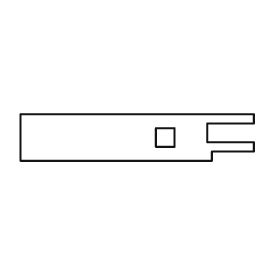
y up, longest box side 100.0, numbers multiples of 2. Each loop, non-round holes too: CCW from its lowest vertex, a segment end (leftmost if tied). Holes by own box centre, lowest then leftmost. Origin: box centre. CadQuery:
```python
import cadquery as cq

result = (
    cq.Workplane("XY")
    .moveTo(-50.0, -10.0)
    .lineTo(32.0, -10.0)
    .lineTo(32.0, -6.0)
    .lineTo(50.0, -6.0)
    .lineTo(50.0, -2.0)
    .lineTo(30.0, -2.0)
    .lineTo(30.0, 6.0)
    .lineTo(50.0, 6.0)
    .lineTo(50.0, 10.0)
    .lineTo(-50.0, 10.0)
    .close()
    .moveTo(8.0, -4.0)
    .lineTo(16.0, -4.0)
    .lineTo(16.0, 4.0)
    .lineTo(8.0, 4.0)
    .close()
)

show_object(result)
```